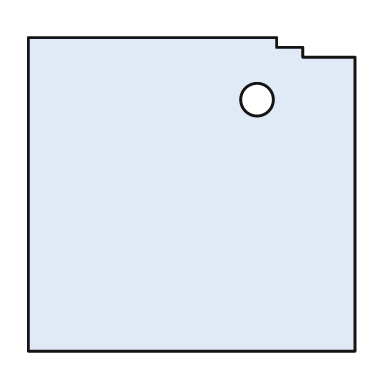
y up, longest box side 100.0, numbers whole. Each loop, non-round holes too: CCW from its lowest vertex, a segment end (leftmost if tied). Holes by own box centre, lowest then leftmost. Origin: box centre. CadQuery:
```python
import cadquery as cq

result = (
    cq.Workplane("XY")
    .moveTo(-50.0, -48.0)
    .lineTo(50.0, -48.0)
    .lineTo(50.0, 42.0)
    .lineTo(34.0, 42.0)
    .lineTo(34.0, 45.0)
    .lineTo(26.0, 45.0)
    .lineTo(26.0, 48.0)
    .lineTo(-50.0, 48.0)
    .close()
    .moveTo(20.0, 29.0)
    .circle(5.0)
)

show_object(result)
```